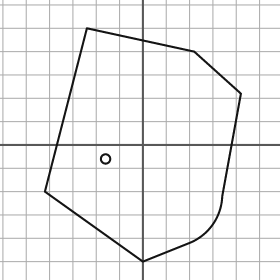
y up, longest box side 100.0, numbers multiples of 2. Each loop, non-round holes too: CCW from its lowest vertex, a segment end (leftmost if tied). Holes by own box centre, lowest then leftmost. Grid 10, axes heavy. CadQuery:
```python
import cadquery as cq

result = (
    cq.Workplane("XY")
    .moveTo(0.0, -50.0)
    .lineTo(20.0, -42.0)
    .threePointArc((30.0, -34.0), (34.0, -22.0))
    .lineTo(42.0, 22.0)
    .lineTo(22.0, 40.0)
    .lineTo(-24.0, 50.0)
    .lineTo(-42.0, -20.0)
    .close()
    .moveTo(-16.0, -6.0)
    .circle(2.0)
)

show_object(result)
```